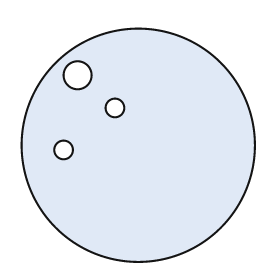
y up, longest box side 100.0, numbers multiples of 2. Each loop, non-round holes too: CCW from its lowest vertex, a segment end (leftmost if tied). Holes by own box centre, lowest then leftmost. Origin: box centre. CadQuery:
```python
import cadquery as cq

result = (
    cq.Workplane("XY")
    .moveTo(0.0, 0.0)
    .circle(50.0)
    .moveTo(-32.0, -2.0)
    .circle(4.0)
    .moveTo(-10.0, 16.0)
    .circle(4.0)
    .moveTo(-26.0, 30.0)
    .circle(6.0)
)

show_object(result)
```